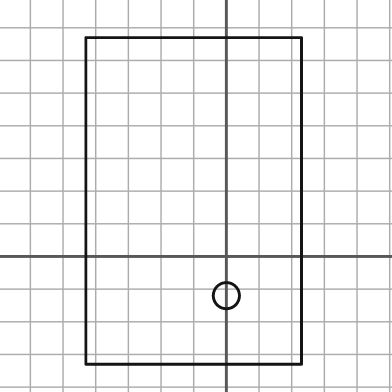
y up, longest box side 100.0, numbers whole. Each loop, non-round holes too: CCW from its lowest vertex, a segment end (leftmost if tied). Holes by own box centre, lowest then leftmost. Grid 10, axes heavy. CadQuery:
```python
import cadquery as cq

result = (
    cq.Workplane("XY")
    .moveTo(-43.0, -33.0)
    .lineTo(23.0, -33.0)
    .lineTo(23.0, 67.0)
    .lineTo(-43.0, 67.0)
    .close()
    .moveTo(0.0, -12.0)
    .circle(4.0)
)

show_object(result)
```